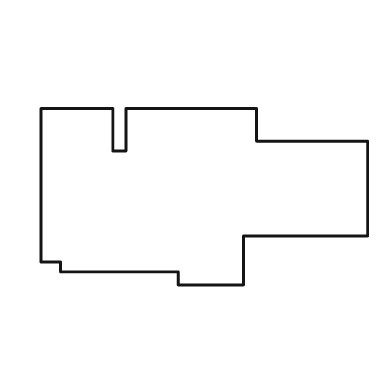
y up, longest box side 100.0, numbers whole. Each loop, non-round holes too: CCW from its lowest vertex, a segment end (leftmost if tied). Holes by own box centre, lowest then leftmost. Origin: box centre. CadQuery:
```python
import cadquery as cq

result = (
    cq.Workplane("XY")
    .moveTo(-8.0, -27.0)
    .lineTo(12.0, -27.0)
    .lineTo(12.0, -12.0)
    .lineTo(50.0, -12.0)
    .lineTo(50.0, 17.0)
    .lineTo(16.0, 17.0)
    .lineTo(16.0, 27.0)
    .lineTo(-24.0, 27.0)
    .lineTo(-24.0, 14.0)
    .lineTo(-28.0, 14.0)
    .lineTo(-28.0, 27.0)
    .lineTo(-50.0, 27.0)
    .lineTo(-50.0, -20.0)
    .lineTo(-44.0, -20.0)
    .lineTo(-44.0, -23.0)
    .lineTo(-8.0, -23.0)
    .close()
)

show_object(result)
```